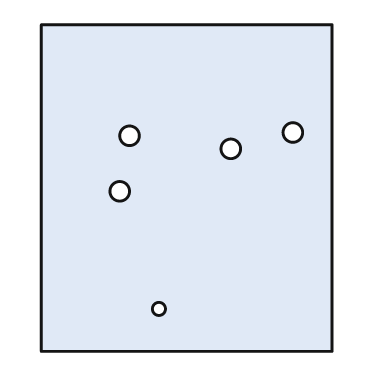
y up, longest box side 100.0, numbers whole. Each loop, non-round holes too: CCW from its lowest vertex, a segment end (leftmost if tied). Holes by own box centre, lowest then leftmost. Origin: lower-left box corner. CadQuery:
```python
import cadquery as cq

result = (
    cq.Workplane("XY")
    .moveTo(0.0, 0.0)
    .lineTo(89.0, 0.0)
    .lineTo(89.0, 100.0)
    .lineTo(0.0, 100.0)
    .close()
    .moveTo(36.0, 13.0)
    .circle(2.0)
    .moveTo(24.0, 49.0)
    .circle(3.0)
    .moveTo(58.0, 62.0)
    .circle(3.0)
    .moveTo(27.0, 66.0)
    .circle(3.0)
    .moveTo(77.0, 67.0)
    .circle(3.0)
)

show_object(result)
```